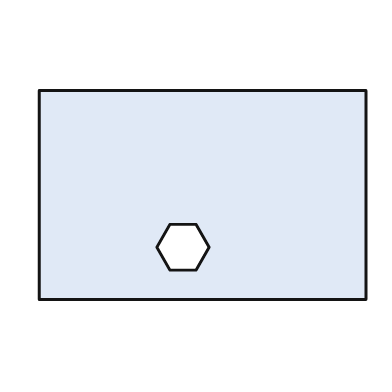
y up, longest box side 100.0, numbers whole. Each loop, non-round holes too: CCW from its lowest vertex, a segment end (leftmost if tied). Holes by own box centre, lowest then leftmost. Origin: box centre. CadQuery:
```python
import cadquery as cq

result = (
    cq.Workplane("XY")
    .moveTo(-50.0, -32.0)
    .lineTo(50.0, -32.0)
    .lineTo(50.0, 32.0)
    .lineTo(-50.0, 32.0)
    .close()
    .moveTo(-10.0, -23.0)
    .lineTo(-2.0, -23.0)
    .lineTo(2.0, -16.0)
    .lineTo(-2.0, -9.0)
    .lineTo(-10.0, -9.0)
    .lineTo(-14.0, -16.0)
    .close()
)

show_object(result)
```